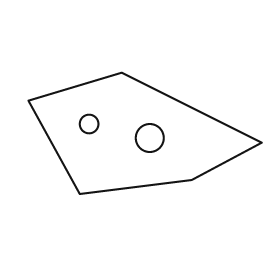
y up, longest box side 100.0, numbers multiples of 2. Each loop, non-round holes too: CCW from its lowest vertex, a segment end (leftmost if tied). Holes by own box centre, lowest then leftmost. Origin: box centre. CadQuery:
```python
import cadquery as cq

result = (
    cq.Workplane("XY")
    .moveTo(-28.0, -26.0)
    .lineTo(20.0, -20.0)
    .lineTo(50.0, -4.0)
    .lineTo(-10.0, 26.0)
    .lineTo(-50.0, 14.0)
    .close()
    .moveTo(2.0, -2.0)
    .circle(6.0)
    .moveTo(-24.0, 4.0)
    .circle(4.0)
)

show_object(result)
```